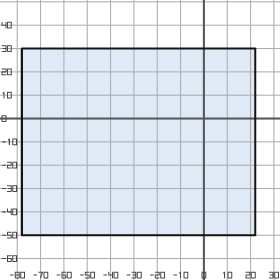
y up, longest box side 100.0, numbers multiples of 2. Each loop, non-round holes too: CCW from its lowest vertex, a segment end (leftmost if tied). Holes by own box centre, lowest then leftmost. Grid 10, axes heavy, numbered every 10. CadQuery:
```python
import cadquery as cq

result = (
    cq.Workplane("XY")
    .moveTo(-78.0, -50.0)
    .lineTo(22.0, -50.0)
    .lineTo(22.0, 30.0)
    .lineTo(-78.0, 30.0)
    .close()
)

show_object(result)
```